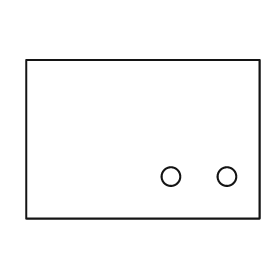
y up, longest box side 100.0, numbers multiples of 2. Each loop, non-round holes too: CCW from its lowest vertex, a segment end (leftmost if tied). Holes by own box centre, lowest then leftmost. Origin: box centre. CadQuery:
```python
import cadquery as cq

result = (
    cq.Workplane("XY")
    .moveTo(-50.0, -34.0)
    .lineTo(50.0, -34.0)
    .lineTo(50.0, 34.0)
    .lineTo(-50.0, 34.0)
    .close()
    .moveTo(12.0, -16.0)
    .circle(4.0)
    .moveTo(36.0, -16.0)
    .circle(4.0)
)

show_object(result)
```